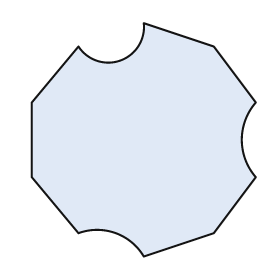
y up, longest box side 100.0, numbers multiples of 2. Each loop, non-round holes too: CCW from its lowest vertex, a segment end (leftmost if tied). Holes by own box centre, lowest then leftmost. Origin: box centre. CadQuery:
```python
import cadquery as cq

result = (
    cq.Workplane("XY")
    .moveTo(0.0, -50.0)
    .lineTo(30.0, -40.0)
    .lineTo(48.0, -16.0)
    .threePointArc((42.0, 0.0), (48.0, 16.0))
    .lineTo(30.0, 40.0)
    .lineTo(0.0, 50.0)
    .threePointArc((-10.0, 34.0), (-28.0, 40.0))
    .lineTo(-48.0, 16.0)
    .lineTo(-48.0, -16.0)
    .lineTo(-28.0, -40.0)
    .threePointArc((-12.0, -40.0), (0.0, -50.0))
    .close()
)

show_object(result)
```